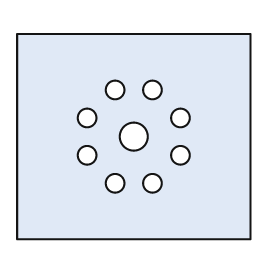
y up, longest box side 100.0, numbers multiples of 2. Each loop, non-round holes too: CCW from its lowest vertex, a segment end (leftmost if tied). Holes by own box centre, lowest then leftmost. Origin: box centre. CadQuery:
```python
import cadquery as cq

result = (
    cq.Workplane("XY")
    .moveTo(-50.0, -44.0)
    .lineTo(50.0, -44.0)
    .lineTo(50.0, 44.0)
    .lineTo(-50.0, 44.0)
    .close()
    .moveTo(-8.0, -20.0)
    .circle(4.0)
    .moveTo(8.0, -20.0)
    .circle(4.0)
    .moveTo(-20.0, -8.0)
    .circle(4.0)
    .moveTo(20.0, -8.0)
    .circle(4.0)
    .moveTo(0.0, 0.0)
    .circle(6.0)
    .moveTo(-20.0, 8.0)
    .circle(4.0)
    .moveTo(20.0, 8.0)
    .circle(4.0)
    .moveTo(-8.0, 20.0)
    .circle(4.0)
    .moveTo(8.0, 20.0)
    .circle(4.0)
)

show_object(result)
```